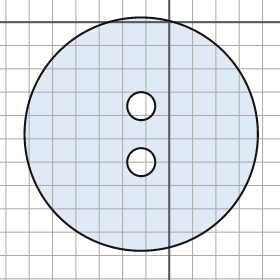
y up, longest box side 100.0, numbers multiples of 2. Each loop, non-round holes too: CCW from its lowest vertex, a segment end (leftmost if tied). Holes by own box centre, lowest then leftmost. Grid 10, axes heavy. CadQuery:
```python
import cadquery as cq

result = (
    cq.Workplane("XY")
    .moveTo(-12.0, -48.0)
    .circle(50.0)
    .moveTo(-12.0, -60.0)
    .circle(6.0)
    .moveTo(-12.0, -36.0)
    .circle(6.0)
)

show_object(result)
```